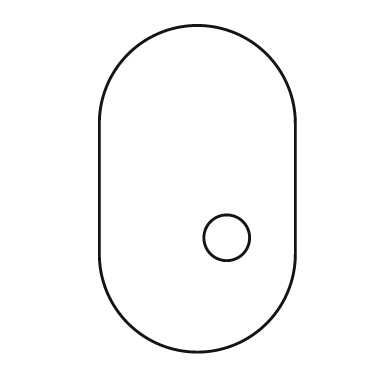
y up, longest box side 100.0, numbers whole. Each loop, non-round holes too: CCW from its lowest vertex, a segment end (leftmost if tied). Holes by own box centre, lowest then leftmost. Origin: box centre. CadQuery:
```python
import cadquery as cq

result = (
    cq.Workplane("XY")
    .moveTo(-30.0, -20.0)
    .threePointArc((0.0, -50.0), (30.0, -20.0))
    .lineTo(30.0, 20.0)
    .threePointArc((0.0, 50.0), (-30.0, 20.0))
    .close()
    .moveTo(9.0, -15.0)
    .circle(7.0)
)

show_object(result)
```